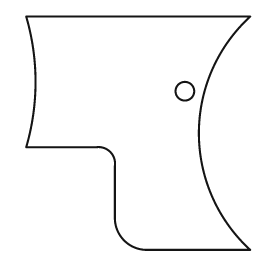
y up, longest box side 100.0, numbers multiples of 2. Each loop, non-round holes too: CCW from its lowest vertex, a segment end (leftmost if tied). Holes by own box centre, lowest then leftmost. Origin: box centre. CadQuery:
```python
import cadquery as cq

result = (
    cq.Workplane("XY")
    .moveTo(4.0, -50.0)
    .lineTo(48.0, -50.0)
    .threePointArc((26.0, 0.0), (48.0, 50.0))
    .lineTo(-48.0, 50.0)
    .threePointArc((-44.0, 22.0), (-48.0, -6.0))
    .lineTo(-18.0, -6.0)
    .threePointArc((-12.0, -8.0), (-10.0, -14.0))
    .lineTo(-10.0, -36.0)
    .threePointArc((-6.0, -46.0), (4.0, -50.0))
    .close()
    .moveTo(20.0, 18.0)
    .circle(4.0)
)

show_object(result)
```